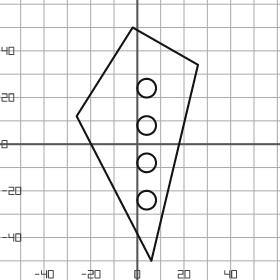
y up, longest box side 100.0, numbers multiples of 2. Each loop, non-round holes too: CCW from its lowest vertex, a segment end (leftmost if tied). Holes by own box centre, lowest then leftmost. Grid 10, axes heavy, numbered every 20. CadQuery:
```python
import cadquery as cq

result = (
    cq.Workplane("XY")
    .moveTo(6.0, -50.0)
    .lineTo(26.0, 34.0)
    .lineTo(-2.0, 50.0)
    .lineTo(-26.0, 12.0)
    .close()
    .moveTo(4.0, -24.0)
    .circle(4.0)
    .moveTo(4.0, -8.0)
    .circle(4.0)
    .moveTo(4.0, 8.0)
    .circle(4.0)
    .moveTo(4.0, 24.0)
    .circle(4.0)
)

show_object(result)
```